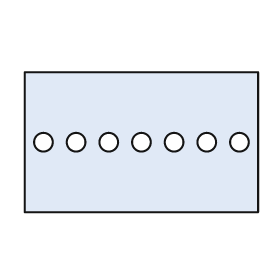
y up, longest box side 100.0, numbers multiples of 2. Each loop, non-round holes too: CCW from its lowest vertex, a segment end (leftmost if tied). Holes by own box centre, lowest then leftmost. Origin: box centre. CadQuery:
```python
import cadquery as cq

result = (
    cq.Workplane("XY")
    .moveTo(-50.0, -30.0)
    .lineTo(50.0, -30.0)
    .lineTo(50.0, 30.0)
    .lineTo(-50.0, 30.0)
    .close()
    .moveTo(-42.0, 0.0)
    .circle(4.0)
    .moveTo(-28.0, 0.0)
    .circle(4.0)
    .moveTo(-14.0, 0.0)
    .circle(4.0)
    .moveTo(0.0, 0.0)
    .circle(4.0)
    .moveTo(14.0, 0.0)
    .circle(4.0)
    .moveTo(28.0, 0.0)
    .circle(4.0)
    .moveTo(42.0, 0.0)
    .circle(4.0)
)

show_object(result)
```